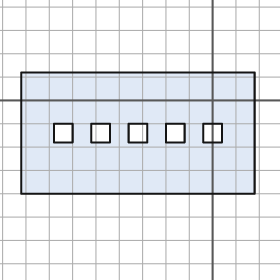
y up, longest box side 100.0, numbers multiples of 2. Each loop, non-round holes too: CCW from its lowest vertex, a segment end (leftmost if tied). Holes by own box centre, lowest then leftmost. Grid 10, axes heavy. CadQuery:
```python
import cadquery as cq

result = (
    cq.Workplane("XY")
    .moveTo(-82.0, -40.0)
    .lineTo(18.0, -40.0)
    .lineTo(18.0, 12.0)
    .lineTo(-82.0, 12.0)
    .close()
    .moveTo(-68.0, -18.0)
    .lineTo(-60.0, -18.0)
    .lineTo(-60.0, -10.0)
    .lineTo(-68.0, -10.0)
    .close()
    .moveTo(-52.0, -18.0)
    .lineTo(-44.0, -18.0)
    .lineTo(-44.0, -10.0)
    .lineTo(-52.0, -10.0)
    .close()
    .moveTo(-36.0, -18.0)
    .lineTo(-28.0, -18.0)
    .lineTo(-28.0, -10.0)
    .lineTo(-36.0, -10.0)
    .close()
    .moveTo(-20.0, -18.0)
    .lineTo(-12.0, -18.0)
    .lineTo(-12.0, -10.0)
    .lineTo(-20.0, -10.0)
    .close()
    .moveTo(-4.0, -18.0)
    .lineTo(4.0, -18.0)
    .lineTo(4.0, -10.0)
    .lineTo(-4.0, -10.0)
    .close()
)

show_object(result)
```